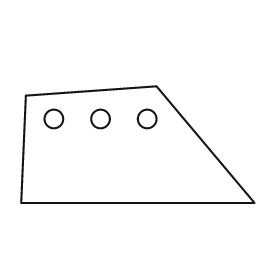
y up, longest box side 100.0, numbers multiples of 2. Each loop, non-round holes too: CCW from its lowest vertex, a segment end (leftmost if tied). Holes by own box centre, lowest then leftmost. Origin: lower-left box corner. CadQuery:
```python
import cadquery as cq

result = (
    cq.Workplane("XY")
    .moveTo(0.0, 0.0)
    .lineTo(100.0, 0.0)
    .lineTo(58.0, 50.0)
    .lineTo(2.0, 46.0)
    .close()
    .moveTo(14.0, 36.0)
    .circle(4.0)
    .moveTo(34.0, 36.0)
    .circle(4.0)
    .moveTo(54.0, 36.0)
    .circle(4.0)
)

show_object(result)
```